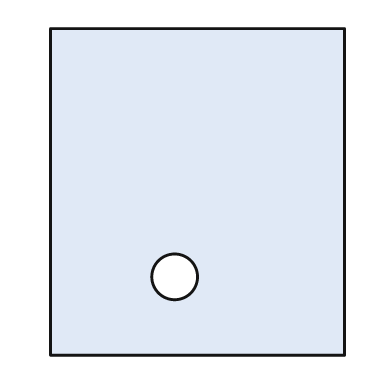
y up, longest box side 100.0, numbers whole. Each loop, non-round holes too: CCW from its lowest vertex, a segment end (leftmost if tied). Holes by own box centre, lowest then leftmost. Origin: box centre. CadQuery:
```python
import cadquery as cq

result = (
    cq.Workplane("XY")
    .moveTo(-45.0, -50.0)
    .lineTo(45.0, -50.0)
    .lineTo(45.0, 50.0)
    .lineTo(-45.0, 50.0)
    .close()
    .moveTo(-7.0, -26.0)
    .circle(7.0)
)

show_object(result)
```